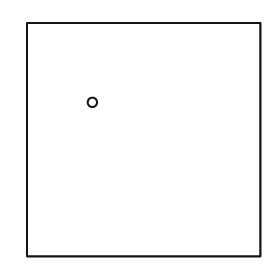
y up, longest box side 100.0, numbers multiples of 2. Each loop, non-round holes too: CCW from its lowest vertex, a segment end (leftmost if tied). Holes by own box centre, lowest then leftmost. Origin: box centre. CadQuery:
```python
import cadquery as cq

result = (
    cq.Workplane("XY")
    .moveTo(-50.0, -50.0)
    .lineTo(50.0, -50.0)
    .lineTo(50.0, 50.0)
    .lineTo(-50.0, 50.0)
    .close()
    .moveTo(-22.0, 16.0)
    .circle(2.0)
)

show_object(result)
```